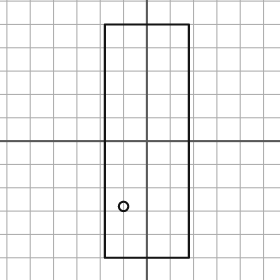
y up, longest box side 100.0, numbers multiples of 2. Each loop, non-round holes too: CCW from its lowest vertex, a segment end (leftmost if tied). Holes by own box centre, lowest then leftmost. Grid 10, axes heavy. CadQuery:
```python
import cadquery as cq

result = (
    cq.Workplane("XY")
    .moveTo(-18.0, -50.0)
    .lineTo(18.0, -50.0)
    .lineTo(18.0, 50.0)
    .lineTo(-18.0, 50.0)
    .close()
    .moveTo(-10.0, -28.0)
    .circle(2.0)
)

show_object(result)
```